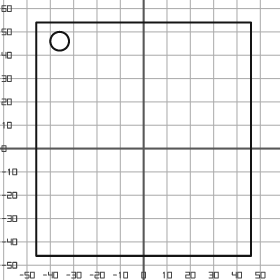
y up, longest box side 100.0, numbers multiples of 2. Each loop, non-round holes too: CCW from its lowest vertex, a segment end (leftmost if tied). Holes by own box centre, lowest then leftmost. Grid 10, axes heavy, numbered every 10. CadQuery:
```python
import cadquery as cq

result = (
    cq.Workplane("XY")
    .moveTo(-46.0, -46.0)
    .lineTo(46.0, -46.0)
    .lineTo(46.0, 54.0)
    .lineTo(-46.0, 54.0)
    .close()
    .moveTo(-36.0, 46.0)
    .circle(4.0)
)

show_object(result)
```